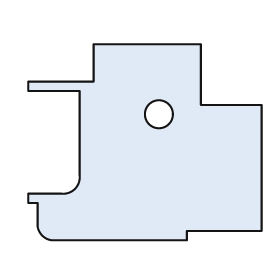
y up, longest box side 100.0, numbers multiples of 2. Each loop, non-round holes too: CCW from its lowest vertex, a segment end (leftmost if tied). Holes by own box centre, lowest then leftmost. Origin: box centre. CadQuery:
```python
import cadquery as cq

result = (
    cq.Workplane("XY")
    .moveTo(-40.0, -42.0)
    .lineTo(18.0, -42.0)
    .lineTo(18.0, -38.0)
    .lineTo(50.0, -38.0)
    .lineTo(50.0, 16.0)
    .lineTo(24.0, 16.0)
    .lineTo(24.0, 42.0)
    .lineTo(-22.0, 42.0)
    .lineTo(-22.0, 26.0)
    .lineTo(-50.0, 26.0)
    .lineTo(-50.0, 22.0)
    .lineTo(-28.0, 22.0)
    .lineTo(-28.0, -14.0)
    .threePointArc((-30.0, -20.0), (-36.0, -22.0))
    .lineTo(-50.0, -22.0)
    .lineTo(-50.0, -26.0)
    .lineTo(-46.0, -26.0)
    .lineTo(-46.0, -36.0)
    .threePointArc((-44.0, -40.0), (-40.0, -42.0))
    .close()
    .moveTo(6.0, 12.0)
    .circle(6.0)
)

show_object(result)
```